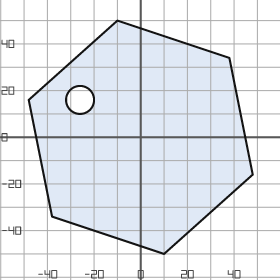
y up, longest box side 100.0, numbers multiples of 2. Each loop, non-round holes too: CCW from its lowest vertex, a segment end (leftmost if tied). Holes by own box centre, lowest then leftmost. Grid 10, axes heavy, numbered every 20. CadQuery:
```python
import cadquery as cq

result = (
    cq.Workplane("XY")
    .moveTo(10.0, -50.0)
    .lineTo(48.0, -16.0)
    .lineTo(38.0, 34.0)
    .lineTo(-10.0, 50.0)
    .lineTo(-48.0, 16.0)
    .lineTo(-38.0, -34.0)
    .close()
    .moveTo(-26.0, 16.0)
    .circle(6.0)
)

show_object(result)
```